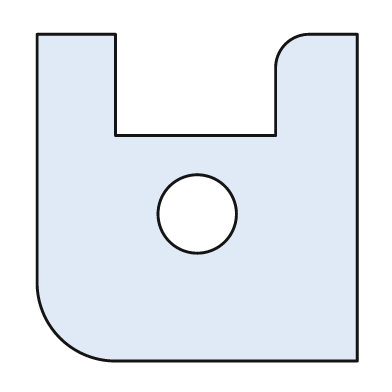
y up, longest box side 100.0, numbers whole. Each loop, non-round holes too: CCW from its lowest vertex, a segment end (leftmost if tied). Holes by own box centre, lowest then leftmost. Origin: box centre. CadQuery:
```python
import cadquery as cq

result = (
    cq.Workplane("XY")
    .moveTo(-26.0, -50.0)
    .lineTo(49.0, -50.0)
    .lineTo(49.0, 50.0)
    .lineTo(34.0, 50.0)
    .threePointArc((27.0, 47.0), (24.0, 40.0))
    .lineTo(24.0, 19.0)
    .lineTo(-25.0, 19.0)
    .lineTo(-25.0, 50.0)
    .lineTo(-49.0, 50.0)
    .lineTo(-49.0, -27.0)
    .threePointArc((-42.0, -43.0), (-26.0, -50.0))
    .close()
    .moveTo(0.0, -5.0)
    .circle(12.0)
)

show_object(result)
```